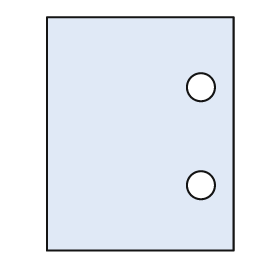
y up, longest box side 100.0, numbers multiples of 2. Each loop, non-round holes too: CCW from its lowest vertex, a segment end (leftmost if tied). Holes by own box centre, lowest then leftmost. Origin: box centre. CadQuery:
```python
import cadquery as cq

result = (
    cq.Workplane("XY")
    .moveTo(-40.0, -50.0)
    .lineTo(40.0, -50.0)
    .lineTo(40.0, 50.0)
    .lineTo(-40.0, 50.0)
    .close()
    .moveTo(26.0, -22.0)
    .circle(6.0)
    .moveTo(26.0, 20.0)
    .circle(6.0)
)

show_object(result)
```